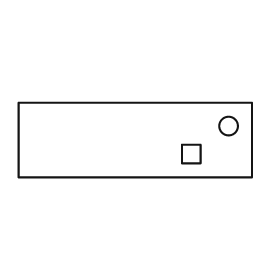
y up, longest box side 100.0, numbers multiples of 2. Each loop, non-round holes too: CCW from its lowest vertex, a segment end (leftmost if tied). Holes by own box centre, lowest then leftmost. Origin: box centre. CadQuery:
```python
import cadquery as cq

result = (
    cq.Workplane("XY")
    .moveTo(-50.0, -16.0)
    .lineTo(50.0, -16.0)
    .lineTo(50.0, 16.0)
    .lineTo(-50.0, 16.0)
    .close()
    .moveTo(20.0, -10.0)
    .lineTo(28.0, -10.0)
    .lineTo(28.0, -2.0)
    .lineTo(20.0, -2.0)
    .close()
    .moveTo(40.0, 6.0)
    .circle(4.0)
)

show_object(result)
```